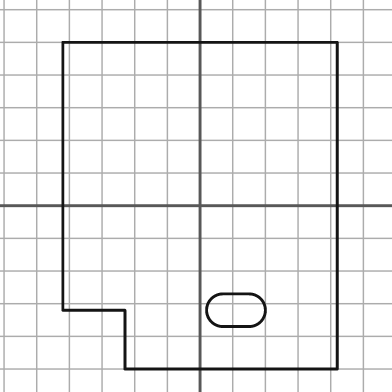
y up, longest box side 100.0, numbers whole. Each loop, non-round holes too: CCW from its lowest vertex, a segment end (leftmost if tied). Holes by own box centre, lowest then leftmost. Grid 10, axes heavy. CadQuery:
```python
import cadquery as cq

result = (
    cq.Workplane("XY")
    .moveTo(-23.0, -50.0)
    .lineTo(42.0, -50.0)
    .lineTo(42.0, 50.0)
    .lineTo(-42.0, 50.0)
    .lineTo(-42.0, -32.0)
    .lineTo(-23.0, -32.0)
    .close()
    .moveTo(7.0, -37.0)
    .lineTo(15.0, -37.0)
    .threePointArc((20.0, -32.0), (15.0, -27.0))
    .lineTo(7.0, -27.0)
    .threePointArc((2.0, -32.0), (7.0, -37.0))
    .close()
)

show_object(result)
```